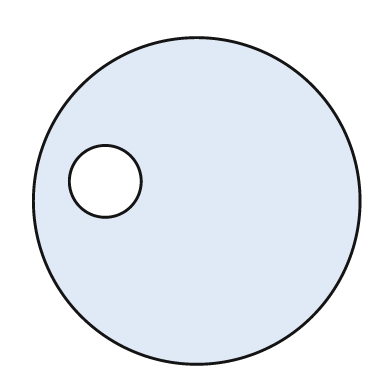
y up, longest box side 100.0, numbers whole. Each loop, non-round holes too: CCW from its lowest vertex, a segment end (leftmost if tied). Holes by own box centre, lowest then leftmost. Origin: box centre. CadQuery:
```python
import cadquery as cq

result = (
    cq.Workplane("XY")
    .moveTo(0.0, 0.0)
    .circle(50.0)
    .moveTo(-28.0, 6.0)
    .circle(11.0)
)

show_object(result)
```